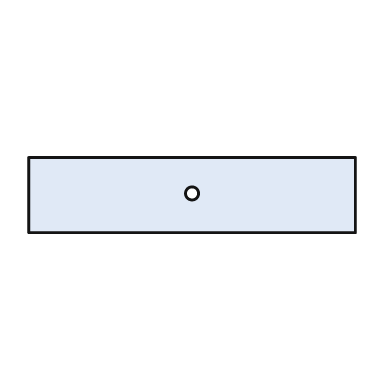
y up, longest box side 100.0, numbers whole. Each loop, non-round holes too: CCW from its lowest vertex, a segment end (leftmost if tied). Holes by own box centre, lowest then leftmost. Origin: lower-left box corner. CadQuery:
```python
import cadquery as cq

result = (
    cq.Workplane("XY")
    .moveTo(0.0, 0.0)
    .lineTo(100.0, 0.0)
    .lineTo(100.0, 23.0)
    .lineTo(0.0, 23.0)
    .close()
    .moveTo(50.0, 12.0)
    .circle(2.0)
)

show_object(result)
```